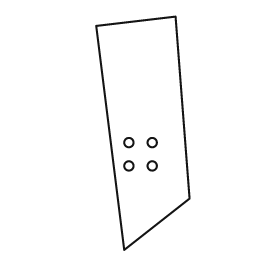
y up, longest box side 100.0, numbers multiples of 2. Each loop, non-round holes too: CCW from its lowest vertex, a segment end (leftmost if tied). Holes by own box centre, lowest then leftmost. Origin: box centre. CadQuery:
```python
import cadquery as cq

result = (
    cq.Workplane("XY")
    .moveTo(-8.0, -50.0)
    .lineTo(20.0, -28.0)
    .lineTo(14.0, 50.0)
    .lineTo(-20.0, 46.0)
    .close()
    .moveTo(-6.0, -14.0)
    .circle(2.0)
    .moveTo(4.0, -14.0)
    .circle(2.0)
    .moveTo(-6.0, -4.0)
    .circle(2.0)
    .moveTo(4.0, -4.0)
    .circle(2.0)
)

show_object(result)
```